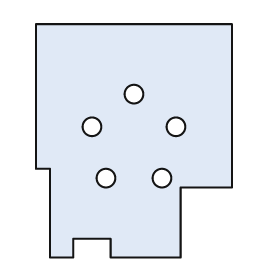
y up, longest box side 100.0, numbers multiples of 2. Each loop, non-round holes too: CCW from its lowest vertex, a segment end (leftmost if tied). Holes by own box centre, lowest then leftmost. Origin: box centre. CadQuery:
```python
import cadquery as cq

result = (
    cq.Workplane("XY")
    .moveTo(-36.0, -50.0)
    .lineTo(-26.0, -50.0)
    .lineTo(-26.0, -42.0)
    .lineTo(-10.0, -42.0)
    .lineTo(-10.0, -50.0)
    .lineTo(20.0, -50.0)
    .lineTo(20.0, -20.0)
    .lineTo(42.0, -20.0)
    .lineTo(42.0, 50.0)
    .lineTo(-42.0, 50.0)
    .lineTo(-42.0, -12.0)
    .lineTo(-36.0, -12.0)
    .close()
    .moveTo(-12.0, -16.0)
    .circle(4.0)
    .moveTo(12.0, -16.0)
    .circle(4.0)
    .moveTo(-18.0, 6.0)
    .circle(4.0)
    .moveTo(18.0, 6.0)
    .circle(4.0)
    .moveTo(0.0, 20.0)
    .circle(4.0)
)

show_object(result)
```